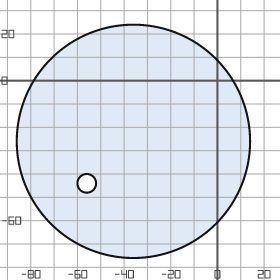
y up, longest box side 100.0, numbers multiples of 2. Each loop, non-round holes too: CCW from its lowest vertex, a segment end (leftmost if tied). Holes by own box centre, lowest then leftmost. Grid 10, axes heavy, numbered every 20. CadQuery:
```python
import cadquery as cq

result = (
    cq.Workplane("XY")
    .moveTo(-36.0, -26.0)
    .circle(50.0)
    .moveTo(-56.0, -44.0)
    .circle(4.0)
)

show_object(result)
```